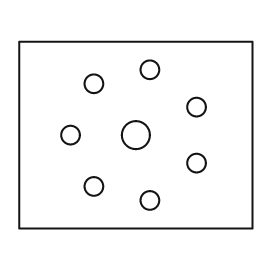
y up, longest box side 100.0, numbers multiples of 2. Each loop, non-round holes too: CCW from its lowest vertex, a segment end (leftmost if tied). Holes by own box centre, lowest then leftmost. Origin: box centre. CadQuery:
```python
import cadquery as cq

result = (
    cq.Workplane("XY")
    .moveTo(-50.0, -40.0)
    .lineTo(50.0, -40.0)
    .lineTo(50.0, 40.0)
    .lineTo(-50.0, 40.0)
    .close()
    .moveTo(6.0, -28.0)
    .circle(4.0)
    .moveTo(-18.0, -22.0)
    .circle(4.0)
    .moveTo(26.0, -12.0)
    .circle(4.0)
    .moveTo(-28.0, 0.0)
    .circle(4.0)
    .moveTo(0.0, 0.0)
    .circle(6.0)
    .moveTo(26.0, 12.0)
    .circle(4.0)
    .moveTo(-18.0, 22.0)
    .circle(4.0)
    .moveTo(6.0, 28.0)
    .circle(4.0)
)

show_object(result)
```